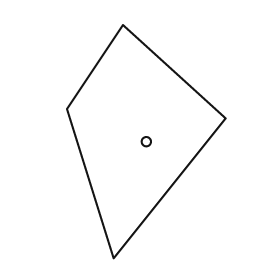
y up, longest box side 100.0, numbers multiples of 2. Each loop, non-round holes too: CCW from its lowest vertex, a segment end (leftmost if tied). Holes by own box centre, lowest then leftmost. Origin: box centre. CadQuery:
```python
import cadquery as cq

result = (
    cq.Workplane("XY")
    .moveTo(-14.0, -50.0)
    .lineTo(34.0, 10.0)
    .lineTo(-10.0, 50.0)
    .lineTo(-34.0, 14.0)
    .close()
    .moveTo(0.0, 0.0)
    .circle(2.0)
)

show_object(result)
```